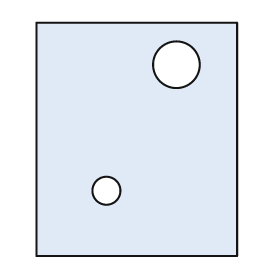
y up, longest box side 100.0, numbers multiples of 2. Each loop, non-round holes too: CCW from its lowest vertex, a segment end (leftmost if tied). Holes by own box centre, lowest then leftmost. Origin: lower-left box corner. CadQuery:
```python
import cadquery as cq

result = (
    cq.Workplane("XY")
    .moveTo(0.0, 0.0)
    .lineTo(86.0, 0.0)
    .lineTo(86.0, 100.0)
    .lineTo(0.0, 100.0)
    .close()
    .moveTo(30.0, 28.0)
    .circle(6.0)
    .moveTo(60.0, 82.0)
    .circle(10.0)
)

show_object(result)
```